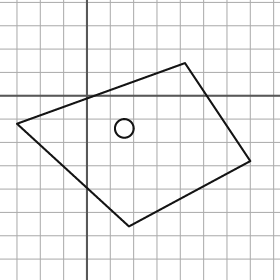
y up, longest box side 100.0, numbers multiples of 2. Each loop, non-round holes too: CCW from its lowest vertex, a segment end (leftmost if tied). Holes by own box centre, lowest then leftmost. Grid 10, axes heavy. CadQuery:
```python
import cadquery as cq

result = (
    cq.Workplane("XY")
    .moveTo(18.0, -56.0)
    .lineTo(70.0, -28.0)
    .lineTo(42.0, 14.0)
    .lineTo(-30.0, -12.0)
    .close()
    .moveTo(16.0, -14.0)
    .circle(4.0)
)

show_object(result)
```